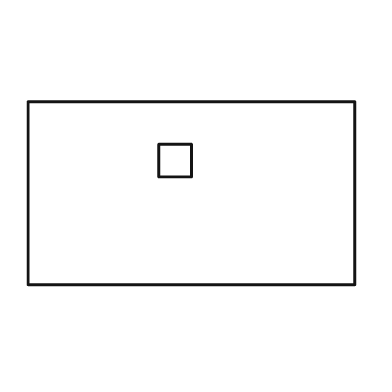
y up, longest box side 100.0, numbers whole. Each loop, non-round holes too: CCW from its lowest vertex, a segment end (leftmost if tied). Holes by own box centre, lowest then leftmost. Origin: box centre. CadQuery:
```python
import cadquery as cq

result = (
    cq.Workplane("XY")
    .moveTo(-50.0, -28.0)
    .lineTo(50.0, -28.0)
    .lineTo(50.0, 28.0)
    .lineTo(-50.0, 28.0)
    .close()
    .moveTo(-10.0, 5.0)
    .lineTo(0.0, 5.0)
    .lineTo(0.0, 15.0)
    .lineTo(-10.0, 15.0)
    .close()
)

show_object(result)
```